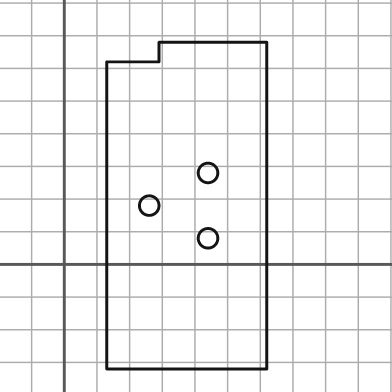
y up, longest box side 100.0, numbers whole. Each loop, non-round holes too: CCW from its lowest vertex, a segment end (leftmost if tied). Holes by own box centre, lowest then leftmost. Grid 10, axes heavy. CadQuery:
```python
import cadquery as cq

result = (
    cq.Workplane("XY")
    .moveTo(13.0, -32.0)
    .lineTo(62.0, -32.0)
    .lineTo(62.0, 68.0)
    .lineTo(29.0, 68.0)
    .lineTo(29.0, 62.0)
    .lineTo(13.0, 62.0)
    .close()
    .moveTo(44.0, 8.0)
    .circle(3.0)
    .moveTo(26.0, 18.0)
    .circle(3.0)
    .moveTo(44.0, 28.0)
    .circle(3.0)
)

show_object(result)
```